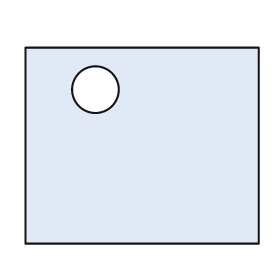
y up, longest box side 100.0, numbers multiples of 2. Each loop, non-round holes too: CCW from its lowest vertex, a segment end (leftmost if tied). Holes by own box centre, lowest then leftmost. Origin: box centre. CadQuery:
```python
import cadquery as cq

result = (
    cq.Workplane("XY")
    .moveTo(-50.0, -42.0)
    .lineTo(50.0, -42.0)
    .lineTo(50.0, 42.0)
    .lineTo(-50.0, 42.0)
    .close()
    .moveTo(-20.0, 24.0)
    .circle(10.0)
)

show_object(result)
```